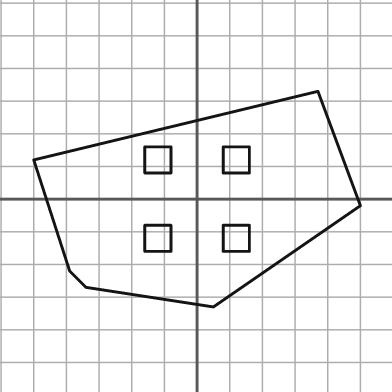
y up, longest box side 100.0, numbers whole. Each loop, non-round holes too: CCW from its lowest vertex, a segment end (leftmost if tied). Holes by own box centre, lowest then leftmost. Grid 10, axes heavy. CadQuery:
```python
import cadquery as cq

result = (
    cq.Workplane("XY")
    .moveTo(5.0, -33.0)
    .lineTo(50.0, -2.0)
    .lineTo(37.0, 33.0)
    .lineTo(-50.0, 12.0)
    .lineTo(-39.0, -22.0)
    .lineTo(-34.0, -27.0)
    .close()
    .moveTo(-16.0, -16.0)
    .lineTo(-8.0, -16.0)
    .lineTo(-8.0, -8.0)
    .lineTo(-16.0, -8.0)
    .close()
    .moveTo(8.0, -16.0)
    .lineTo(16.0, -16.0)
    .lineTo(16.0, -8.0)
    .lineTo(8.0, -8.0)
    .close()
    .moveTo(-16.0, 8.0)
    .lineTo(-8.0, 8.0)
    .lineTo(-8.0, 16.0)
    .lineTo(-16.0, 16.0)
    .close()
    .moveTo(8.0, 8.0)
    .lineTo(16.0, 8.0)
    .lineTo(16.0, 16.0)
    .lineTo(8.0, 16.0)
    .close()
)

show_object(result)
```